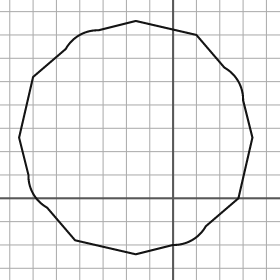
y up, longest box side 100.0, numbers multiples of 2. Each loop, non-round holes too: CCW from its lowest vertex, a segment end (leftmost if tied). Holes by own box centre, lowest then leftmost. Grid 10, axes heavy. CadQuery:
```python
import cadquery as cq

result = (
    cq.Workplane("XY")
    .moveTo(-16.0, -24.0)
    .lineTo(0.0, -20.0)
    .threePointArc((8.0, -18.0), (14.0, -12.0))
    .lineTo(28.0, 0.0)
    .lineTo(34.0, 26.0)
    .lineTo(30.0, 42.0)
    .threePointArc((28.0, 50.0), (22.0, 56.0))
    .lineTo(10.0, 70.0)
    .lineTo(-16.0, 76.0)
    .lineTo(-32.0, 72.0)
    .threePointArc((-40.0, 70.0), (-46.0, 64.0))
    .lineTo(-60.0, 52.0)
    .lineTo(-66.0, 26.0)
    .lineTo(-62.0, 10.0)
    .threePointArc((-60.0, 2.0), (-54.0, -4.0))
    .lineTo(-42.0, -18.0)
    .close()
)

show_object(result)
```